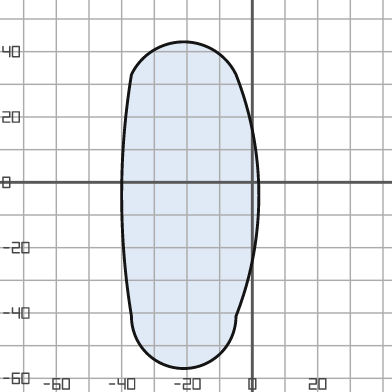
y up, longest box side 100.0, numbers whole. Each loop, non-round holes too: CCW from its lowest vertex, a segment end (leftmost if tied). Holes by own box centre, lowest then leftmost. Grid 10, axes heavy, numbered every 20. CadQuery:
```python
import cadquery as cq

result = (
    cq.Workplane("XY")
    .moveTo(-37.0, -41.0)
    .threePointArc((-21.0, -57.0), (-5.0, -41.0))
    .threePointArc((2.0, -4.0), (-5.0, 33.0))
    .threePointArc((-21.0, 43.0), (-37.0, 33.0))
    .threePointArc((-40.0, -4.0), (-37.0, -41.0))
    .close()
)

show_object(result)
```